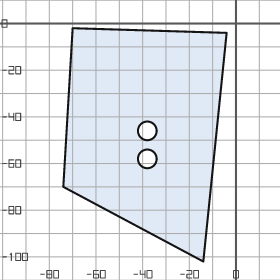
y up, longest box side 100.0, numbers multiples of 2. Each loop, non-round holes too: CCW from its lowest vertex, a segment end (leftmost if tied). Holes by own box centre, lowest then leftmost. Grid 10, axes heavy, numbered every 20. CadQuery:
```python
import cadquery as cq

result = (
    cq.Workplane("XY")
    .moveTo(-14.0, -102.0)
    .lineTo(-4.0, -4.0)
    .lineTo(-70.0, -2.0)
    .lineTo(-74.0, -70.0)
    .close()
    .moveTo(-38.0, -58.0)
    .circle(4.0)
    .moveTo(-38.0, -46.0)
    .circle(4.0)
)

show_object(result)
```